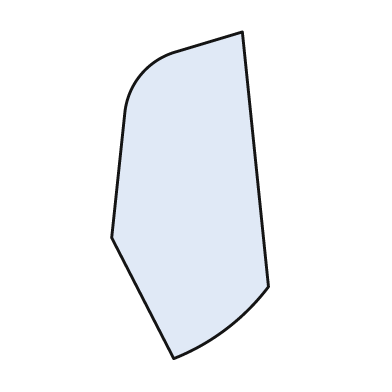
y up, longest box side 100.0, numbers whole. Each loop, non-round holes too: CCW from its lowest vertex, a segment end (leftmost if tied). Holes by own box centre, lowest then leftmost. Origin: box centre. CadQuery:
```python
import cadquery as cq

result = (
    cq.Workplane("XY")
    .moveTo(-5.0, -50.0)
    .threePointArc((11.0, -41.0), (24.0, -28.0))
    .lineTo(16.0, 50.0)
    .lineTo(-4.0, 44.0)
    .threePointArc((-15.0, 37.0), (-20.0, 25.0))
    .lineTo(-24.0, -13.0)
    .close()
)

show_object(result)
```